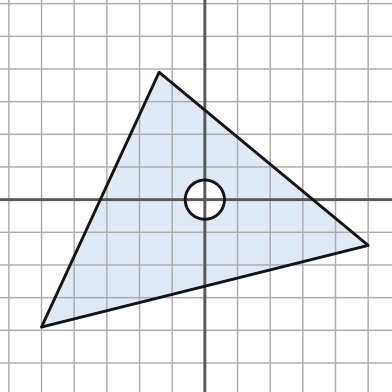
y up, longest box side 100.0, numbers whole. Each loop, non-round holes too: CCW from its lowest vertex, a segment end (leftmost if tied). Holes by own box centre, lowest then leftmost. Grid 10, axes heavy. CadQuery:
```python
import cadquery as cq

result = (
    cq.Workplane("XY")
    .moveTo(-50.0, -39.0)
    .lineTo(50.0, -14.0)
    .lineTo(-14.0, 39.0)
    .close()
    .moveTo(0.0, 0.0)
    .circle(6.0)
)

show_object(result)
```